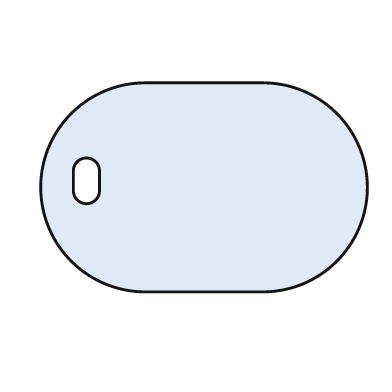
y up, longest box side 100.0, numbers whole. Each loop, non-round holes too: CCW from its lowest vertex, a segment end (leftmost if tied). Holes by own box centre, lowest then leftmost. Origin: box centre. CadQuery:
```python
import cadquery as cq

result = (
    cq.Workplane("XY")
    .moveTo(-18.0, -32.0)
    .lineTo(18.0, -32.0)
    .threePointArc((50.0, 0.0), (18.0, 32.0))
    .lineTo(-18.0, 32.0)
    .threePointArc((-50.0, 0.0), (-18.0, -32.0))
    .close()
    .moveTo(-40.0, -1.0)
    .threePointArc((-36.0, -5.0), (-32.0, -1.0))
    .lineTo(-32.0, 5.0)
    .threePointArc((-36.0, 9.0), (-40.0, 5.0))
    .close()
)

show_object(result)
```